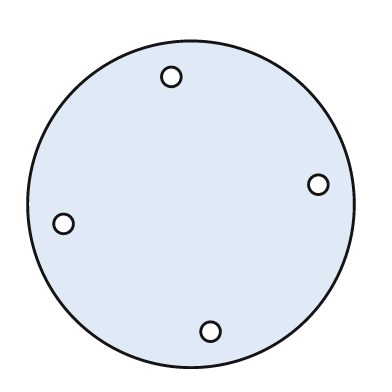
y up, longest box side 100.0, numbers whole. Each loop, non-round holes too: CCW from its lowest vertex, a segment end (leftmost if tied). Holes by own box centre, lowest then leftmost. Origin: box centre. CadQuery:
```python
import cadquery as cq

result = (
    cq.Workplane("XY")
    .moveTo(0.0, 0.0)
    .circle(50.0)
    .moveTo(6.0, -39.0)
    .circle(3.0)
    .moveTo(-39.0, -6.0)
    .circle(3.0)
    .moveTo(39.0, 6.0)
    .circle(3.0)
    .moveTo(-6.0, 39.0)
    .circle(3.0)
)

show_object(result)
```